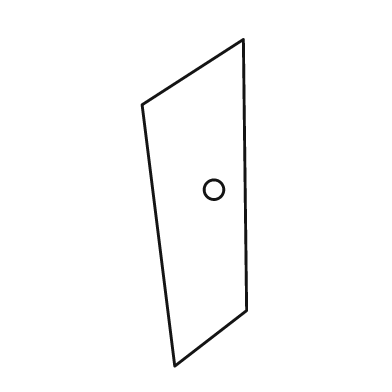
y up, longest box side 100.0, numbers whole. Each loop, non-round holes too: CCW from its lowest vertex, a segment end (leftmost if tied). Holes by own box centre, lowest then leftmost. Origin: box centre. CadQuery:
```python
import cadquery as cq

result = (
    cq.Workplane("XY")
    .moveTo(-6.0, -50.0)
    .lineTo(16.0, -33.0)
    .lineTo(15.0, 50.0)
    .lineTo(-16.0, 30.0)
    .close()
    .moveTo(6.0, 4.0)
    .circle(3.0)
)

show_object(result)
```